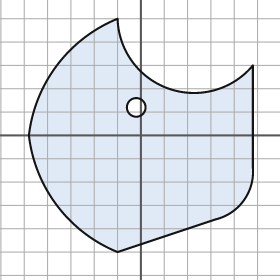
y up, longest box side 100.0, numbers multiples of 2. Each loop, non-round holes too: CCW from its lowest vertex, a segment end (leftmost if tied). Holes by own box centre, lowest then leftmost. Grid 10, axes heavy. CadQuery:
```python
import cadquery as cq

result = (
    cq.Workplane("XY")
    .moveTo(-10.0, -50.0)
    .lineTo(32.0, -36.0)
    .threePointArc((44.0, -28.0), (48.0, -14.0))
    .lineTo(48.0, 30.0)
    .threePointArc((12.0, 20.0), (-10.0, 50.0))
    .threePointArc((-36.0, 30.0), (-48.0, 0.0))
    .threePointArc((-36.0, -30.0), (-10.0, -50.0))
    .close()
    .moveTo(-2.0, 12.0)
    .circle(4.0)
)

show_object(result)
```